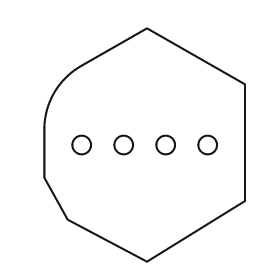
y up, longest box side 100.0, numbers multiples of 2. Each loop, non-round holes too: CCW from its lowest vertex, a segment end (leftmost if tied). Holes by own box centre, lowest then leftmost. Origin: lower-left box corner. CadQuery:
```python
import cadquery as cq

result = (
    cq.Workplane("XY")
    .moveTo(44.0, 0.0)
    .lineTo(86.0, 26.0)
    .lineTo(86.0, 76.0)
    .lineTo(44.0, 100.0)
    .lineTo(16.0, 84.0)
    .threePointArc((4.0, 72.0), (0.0, 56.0))
    .lineTo(0.0, 36.0)
    .lineTo(10.0, 18.0)
    .close()
    .moveTo(16.0, 50.0)
    .circle(4.0)
    .moveTo(34.0, 50.0)
    .circle(4.0)
    .moveTo(52.0, 50.0)
    .circle(4.0)
    .moveTo(70.0, 50.0)
    .circle(4.0)
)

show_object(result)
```